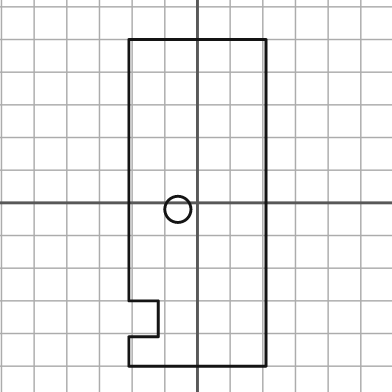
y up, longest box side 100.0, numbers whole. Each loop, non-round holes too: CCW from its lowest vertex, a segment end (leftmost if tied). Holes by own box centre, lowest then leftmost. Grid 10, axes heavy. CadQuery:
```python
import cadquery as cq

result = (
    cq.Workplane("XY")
    .moveTo(-21.0, -50.0)
    .lineTo(21.0, -50.0)
    .lineTo(21.0, 50.0)
    .lineTo(-21.0, 50.0)
    .lineTo(-21.0, -30.0)
    .lineTo(-12.0, -30.0)
    .lineTo(-12.0, -41.0)
    .lineTo(-21.0, -41.0)
    .close()
    .moveTo(-6.0, -2.0)
    .circle(4.0)
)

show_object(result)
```